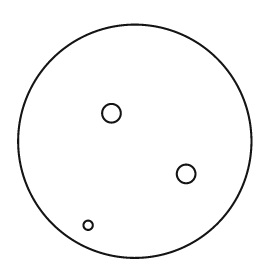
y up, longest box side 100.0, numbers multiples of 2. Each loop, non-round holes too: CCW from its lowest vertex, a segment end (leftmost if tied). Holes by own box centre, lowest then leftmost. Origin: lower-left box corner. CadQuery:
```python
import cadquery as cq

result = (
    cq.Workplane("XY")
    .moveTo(50.0, 50.0)
    .circle(50.0)
    .moveTo(30.0, 14.0)
    .circle(2.0)
    .moveTo(72.0, 36.0)
    .circle(4.0)
    .moveTo(40.0, 62.0)
    .circle(4.0)
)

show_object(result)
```